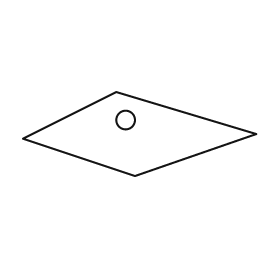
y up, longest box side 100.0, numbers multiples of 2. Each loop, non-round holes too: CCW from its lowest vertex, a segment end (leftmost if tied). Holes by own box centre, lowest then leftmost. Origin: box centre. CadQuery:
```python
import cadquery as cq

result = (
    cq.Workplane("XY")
    .moveTo(-2.0, -18.0)
    .lineTo(50.0, 0.0)
    .lineTo(-10.0, 18.0)
    .lineTo(-50.0, -2.0)
    .close()
    .moveTo(-6.0, 6.0)
    .circle(4.0)
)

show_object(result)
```